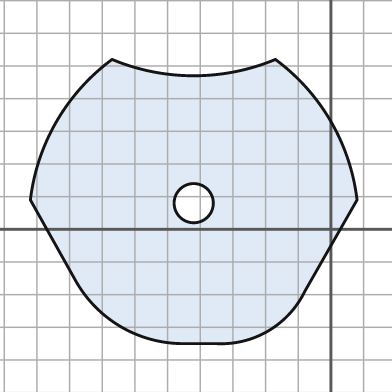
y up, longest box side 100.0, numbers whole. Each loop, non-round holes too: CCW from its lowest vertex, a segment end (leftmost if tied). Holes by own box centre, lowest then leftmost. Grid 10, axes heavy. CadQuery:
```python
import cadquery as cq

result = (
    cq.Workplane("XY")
    .moveTo(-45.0, -35.0)
    .lineTo(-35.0, -35.0)
    .threePointArc((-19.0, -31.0), (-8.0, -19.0))
    .lineTo(8.0, 9.0)
    .threePointArc((0.0, 33.0), (-17.0, 52.0))
    .threePointArc((-42.0, 47.0), (-67.0, 52.0))
    .threePointArc((-84.0, 33.0), (-92.0, 9.0))
    .lineTo(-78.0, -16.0)
    .threePointArc((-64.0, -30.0), (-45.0, -35.0))
    .close()
    .moveTo(-42.0, 8.0)
    .circle(6.0)
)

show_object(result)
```